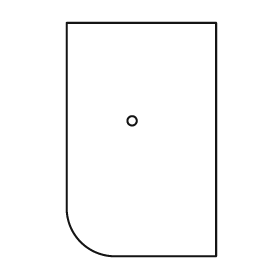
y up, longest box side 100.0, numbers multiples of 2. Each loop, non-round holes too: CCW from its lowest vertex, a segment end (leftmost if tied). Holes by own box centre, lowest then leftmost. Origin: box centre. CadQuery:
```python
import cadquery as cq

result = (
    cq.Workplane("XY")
    .moveTo(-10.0, -50.0)
    .lineTo(32.0, -50.0)
    .lineTo(32.0, 50.0)
    .lineTo(-32.0, 50.0)
    .lineTo(-32.0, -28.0)
    .threePointArc((-26.0, -44.0), (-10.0, -50.0))
    .close()
    .moveTo(-4.0, 8.0)
    .circle(2.0)
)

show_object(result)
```